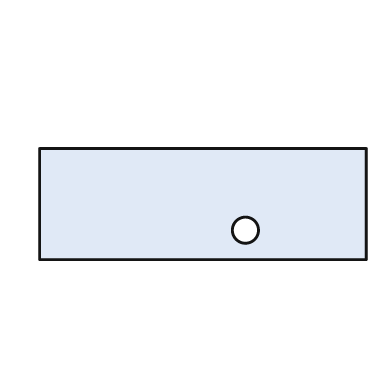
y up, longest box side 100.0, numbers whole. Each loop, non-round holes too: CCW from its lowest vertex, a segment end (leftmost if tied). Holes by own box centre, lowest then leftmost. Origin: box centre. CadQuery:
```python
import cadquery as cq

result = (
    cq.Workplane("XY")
    .moveTo(-50.0, -17.0)
    .lineTo(50.0, -17.0)
    .lineTo(50.0, 17.0)
    .lineTo(-50.0, 17.0)
    .close()
    .moveTo(13.0, -8.0)
    .circle(4.0)
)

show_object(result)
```